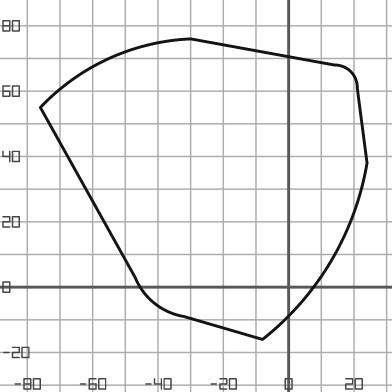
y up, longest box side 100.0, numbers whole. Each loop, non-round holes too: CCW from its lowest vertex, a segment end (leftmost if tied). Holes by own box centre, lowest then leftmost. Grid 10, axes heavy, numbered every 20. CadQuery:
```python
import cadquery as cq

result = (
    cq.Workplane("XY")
    .moveTo(-8.0, -16.0)
    .threePointArc((13.0, 8.0), (24.0, 38.0))
    .lineTo(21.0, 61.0)
    .threePointArc((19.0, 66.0), (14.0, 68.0))
    .lineTo(-30.0, 76.0)
    .threePointArc((-55.0, 70.0), (-76.0, 55.0))
    .lineTo(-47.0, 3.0)
    .threePointArc((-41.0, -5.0), (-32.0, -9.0))
    .close()
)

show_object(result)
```